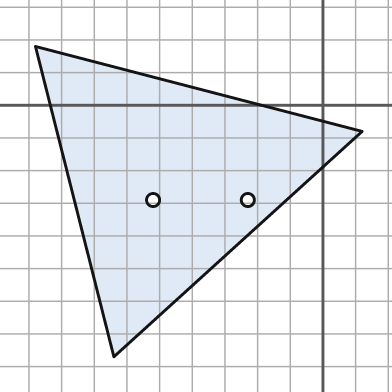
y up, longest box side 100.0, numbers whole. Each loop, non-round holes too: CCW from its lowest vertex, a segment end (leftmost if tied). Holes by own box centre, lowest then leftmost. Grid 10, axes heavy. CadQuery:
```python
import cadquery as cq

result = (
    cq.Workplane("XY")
    .moveTo(-64.0, -77.0)
    .lineTo(12.0, -8.0)
    .lineTo(-88.0, 18.0)
    .close()
    .moveTo(-52.0, -29.0)
    .circle(2.0)
    .moveTo(-23.0, -29.0)
    .circle(2.0)
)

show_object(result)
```